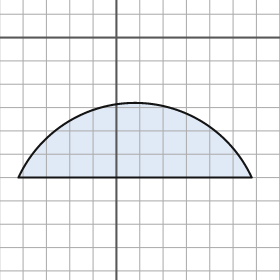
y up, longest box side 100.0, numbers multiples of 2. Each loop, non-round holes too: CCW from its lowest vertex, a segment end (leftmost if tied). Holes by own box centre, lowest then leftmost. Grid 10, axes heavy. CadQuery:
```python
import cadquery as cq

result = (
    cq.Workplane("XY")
    .moveTo(-42.0, -60.0)
    .lineTo(58.0, -60.0)
    .threePointArc((8.0, -28.0), (-42.0, -60.0))
    .close()
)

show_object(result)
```